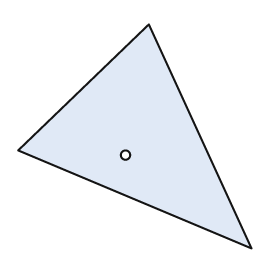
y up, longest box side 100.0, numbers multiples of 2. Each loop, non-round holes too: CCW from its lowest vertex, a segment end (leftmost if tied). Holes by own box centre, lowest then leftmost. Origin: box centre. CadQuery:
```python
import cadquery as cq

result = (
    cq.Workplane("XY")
    .moveTo(50.0, -48.0)
    .lineTo(6.0, 48.0)
    .lineTo(-50.0, -6.0)
    .close()
    .moveTo(-4.0, -8.0)
    .circle(2.0)
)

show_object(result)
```